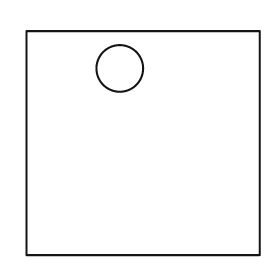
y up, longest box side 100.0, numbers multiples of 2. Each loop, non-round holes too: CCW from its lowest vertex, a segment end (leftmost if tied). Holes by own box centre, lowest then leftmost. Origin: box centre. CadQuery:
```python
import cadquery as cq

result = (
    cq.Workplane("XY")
    .moveTo(-50.0, -48.0)
    .lineTo(50.0, -48.0)
    .lineTo(50.0, 48.0)
    .lineTo(-50.0, 48.0)
    .close()
    .moveTo(-10.0, 32.0)
    .circle(10.0)
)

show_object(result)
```